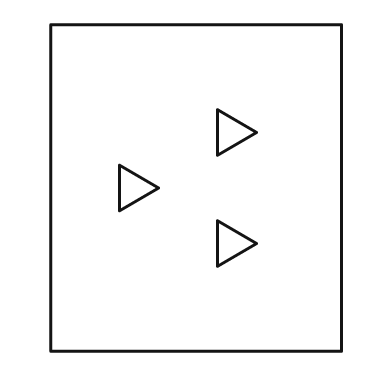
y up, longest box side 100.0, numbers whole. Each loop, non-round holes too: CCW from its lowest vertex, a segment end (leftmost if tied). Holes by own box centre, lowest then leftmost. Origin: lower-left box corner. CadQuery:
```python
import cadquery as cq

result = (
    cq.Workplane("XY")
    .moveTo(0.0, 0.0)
    .lineTo(89.0, 0.0)
    .lineTo(89.0, 100.0)
    .lineTo(0.0, 100.0)
    .close()
    .moveTo(51.0, 26.0)
    .lineTo(63.0, 33.0)
    .lineTo(51.0, 40.0)
    .close()
    .moveTo(21.0, 43.0)
    .lineTo(33.0, 50.0)
    .lineTo(21.0, 57.0)
    .close()
    .moveTo(51.0, 60.0)
    .lineTo(63.0, 67.0)
    .lineTo(51.0, 74.0)
    .close()
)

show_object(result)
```